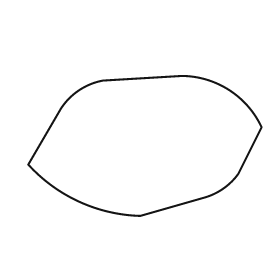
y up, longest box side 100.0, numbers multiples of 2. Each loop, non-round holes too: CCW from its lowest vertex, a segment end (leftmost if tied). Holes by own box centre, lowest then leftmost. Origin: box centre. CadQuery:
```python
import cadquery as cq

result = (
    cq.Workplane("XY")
    .moveTo(-2.0, -30.0)
    .lineTo(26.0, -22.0)
    .threePointArc((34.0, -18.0), (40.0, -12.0))
    .lineTo(50.0, 8.0)
    .threePointArc((36.0, 24.0), (16.0, 30.0))
    .lineTo(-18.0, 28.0)
    .threePointArc((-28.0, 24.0), (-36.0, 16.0))
    .lineTo(-50.0, -8.0)
    .threePointArc((-28.0, -24.0), (-2.0, -30.0))
    .close()
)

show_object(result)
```